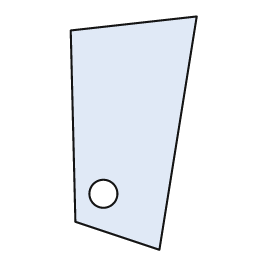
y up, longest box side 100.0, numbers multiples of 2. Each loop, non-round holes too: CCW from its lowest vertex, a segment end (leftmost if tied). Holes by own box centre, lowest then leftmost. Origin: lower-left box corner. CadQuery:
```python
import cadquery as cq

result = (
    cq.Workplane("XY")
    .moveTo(38.0, 0.0)
    .lineTo(54.0, 100.0)
    .lineTo(0.0, 94.0)
    .lineTo(2.0, 12.0)
    .close()
    .moveTo(14.0, 24.0)
    .circle(6.0)
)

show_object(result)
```